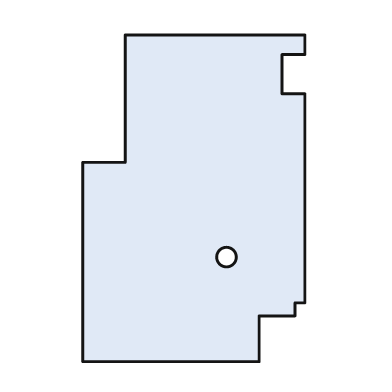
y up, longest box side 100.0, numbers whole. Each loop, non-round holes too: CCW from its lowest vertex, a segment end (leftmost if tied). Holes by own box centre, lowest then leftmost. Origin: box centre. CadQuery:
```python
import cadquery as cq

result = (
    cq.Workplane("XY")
    .moveTo(-34.0, -50.0)
    .lineTo(20.0, -50.0)
    .lineTo(20.0, -36.0)
    .lineTo(31.0, -36.0)
    .lineTo(31.0, -32.0)
    .lineTo(34.0, -32.0)
    .lineTo(34.0, 32.0)
    .lineTo(27.0, 32.0)
    .lineTo(27.0, 44.0)
    .lineTo(34.0, 44.0)
    .lineTo(34.0, 50.0)
    .lineTo(-21.0, 50.0)
    .lineTo(-21.0, 11.0)
    .lineTo(-34.0, 11.0)
    .close()
    .moveTo(10.0, -18.0)
    .circle(3.0)
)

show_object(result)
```